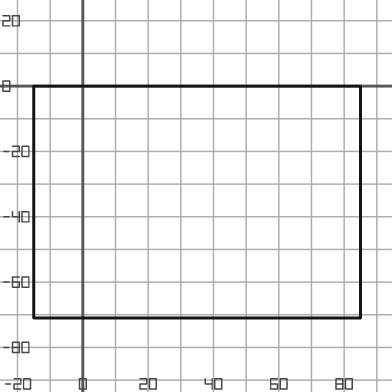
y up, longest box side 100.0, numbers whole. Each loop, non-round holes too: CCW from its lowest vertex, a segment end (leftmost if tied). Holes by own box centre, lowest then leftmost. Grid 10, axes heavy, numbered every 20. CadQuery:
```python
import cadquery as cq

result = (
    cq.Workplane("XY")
    .moveTo(-15.0, -71.0)
    .lineTo(85.0, -71.0)
    .lineTo(85.0, 0.0)
    .lineTo(-15.0, 0.0)
    .close()
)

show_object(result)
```